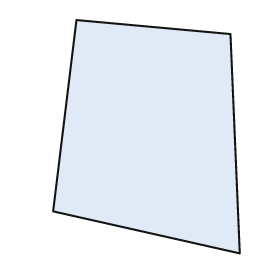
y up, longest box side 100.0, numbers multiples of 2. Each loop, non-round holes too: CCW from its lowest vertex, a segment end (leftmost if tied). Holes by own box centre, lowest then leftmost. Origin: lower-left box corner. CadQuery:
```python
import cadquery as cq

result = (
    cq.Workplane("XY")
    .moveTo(80.0, 0.0)
    .lineTo(76.0, 94.0)
    .lineTo(10.0, 100.0)
    .lineTo(0.0, 18.0)
    .close()
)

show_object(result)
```